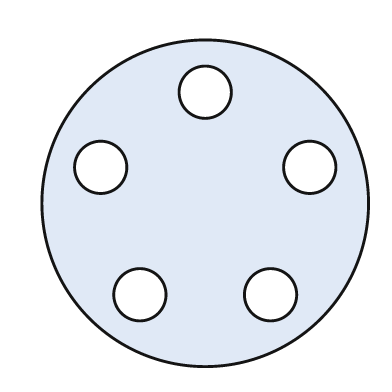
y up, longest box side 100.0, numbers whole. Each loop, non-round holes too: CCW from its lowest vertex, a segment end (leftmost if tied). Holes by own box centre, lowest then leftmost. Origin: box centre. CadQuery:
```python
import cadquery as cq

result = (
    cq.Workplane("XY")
    .moveTo(0.0, 0.0)
    .circle(50.0)
    .moveTo(-20.0, -28.0)
    .circle(8.0)
    .moveTo(20.0, -28.0)
    .circle(8.0)
    .moveTo(-32.0, 11.0)
    .circle(8.0)
    .moveTo(32.0, 11.0)
    .circle(8.0)
    .moveTo(0.0, 34.0)
    .circle(8.0)
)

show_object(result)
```